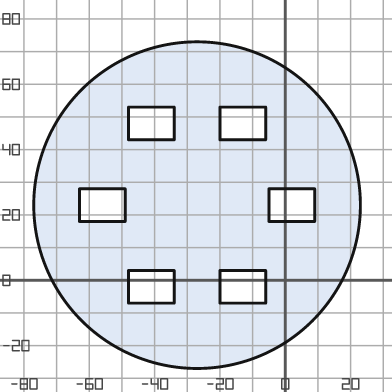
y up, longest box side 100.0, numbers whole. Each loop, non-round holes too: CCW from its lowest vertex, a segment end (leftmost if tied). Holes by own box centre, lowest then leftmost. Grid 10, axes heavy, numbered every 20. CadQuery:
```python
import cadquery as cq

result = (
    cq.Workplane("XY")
    .moveTo(-27.0, 23.0)
    .circle(50.0)
    .moveTo(-48.0, -7.0)
    .lineTo(-34.0, -7.0)
    .lineTo(-34.0, 3.0)
    .lineTo(-48.0, 3.0)
    .close()
    .moveTo(-20.0, -7.0)
    .lineTo(-6.0, -7.0)
    .lineTo(-6.0, 3.0)
    .lineTo(-20.0, 3.0)
    .close()
    .moveTo(-63.0, 18.0)
    .lineTo(-49.0, 18.0)
    .lineTo(-49.0, 28.0)
    .lineTo(-63.0, 28.0)
    .close()
    .moveTo(-5.0, 18.0)
    .lineTo(9.0, 18.0)
    .lineTo(9.0, 28.0)
    .lineTo(-5.0, 28.0)
    .close()
    .moveTo(-48.0, 43.0)
    .lineTo(-34.0, 43.0)
    .lineTo(-34.0, 53.0)
    .lineTo(-48.0, 53.0)
    .close()
    .moveTo(-20.0, 43.0)
    .lineTo(-6.0, 43.0)
    .lineTo(-6.0, 53.0)
    .lineTo(-20.0, 53.0)
    .close()
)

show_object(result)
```